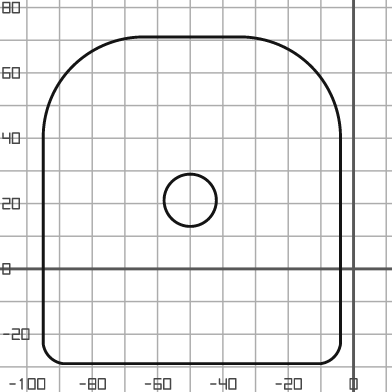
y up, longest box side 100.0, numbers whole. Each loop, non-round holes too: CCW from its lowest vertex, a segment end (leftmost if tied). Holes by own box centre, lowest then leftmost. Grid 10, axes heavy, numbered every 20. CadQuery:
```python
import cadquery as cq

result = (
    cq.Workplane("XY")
    .moveTo(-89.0, -29.0)
    .lineTo(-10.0, -29.0)
    .threePointArc((-6.0, -27.0), (-4.0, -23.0))
    .lineTo(-4.0, 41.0)
    .threePointArc((-13.0, 62.0), (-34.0, 71.0))
    .lineTo(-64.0, 71.0)
    .threePointArc((-86.0, 62.0), (-95.0, 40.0))
    .lineTo(-95.0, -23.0)
    .threePointArc((-93.0, -27.0), (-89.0, -29.0))
    .close()
    .moveTo(-50.0, 21.0)
    .circle(8.0)
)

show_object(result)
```